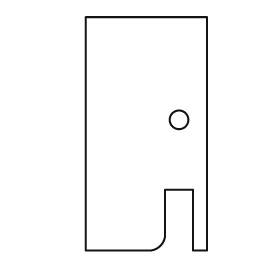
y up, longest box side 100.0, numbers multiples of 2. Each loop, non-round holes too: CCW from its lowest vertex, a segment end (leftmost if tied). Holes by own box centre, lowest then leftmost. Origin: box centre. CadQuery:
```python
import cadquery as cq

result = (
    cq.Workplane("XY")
    .moveTo(-26.0, -50.0)
    .lineTo(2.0, -50.0)
    .threePointArc((6.0, -48.0), (8.0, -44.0))
    .lineTo(8.0, -24.0)
    .lineTo(20.0, -24.0)
    .lineTo(20.0, -50.0)
    .lineTo(26.0, -50.0)
    .lineTo(26.0, 50.0)
    .lineTo(-26.0, 50.0)
    .close()
    .moveTo(14.0, 6.0)
    .circle(4.0)
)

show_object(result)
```